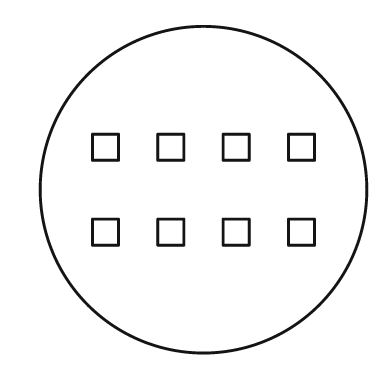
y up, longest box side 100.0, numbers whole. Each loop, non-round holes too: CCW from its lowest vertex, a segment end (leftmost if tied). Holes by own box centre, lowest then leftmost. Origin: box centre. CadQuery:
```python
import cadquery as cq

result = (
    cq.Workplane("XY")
    .moveTo(0.0, 0.0)
    .circle(50.0)
    .moveTo(-34.0, -17.0)
    .lineTo(-26.0, -17.0)
    .lineTo(-26.0, -9.0)
    .lineTo(-34.0, -9.0)
    .close()
    .moveTo(-14.0, -17.0)
    .lineTo(-6.0, -17.0)
    .lineTo(-6.0, -9.0)
    .lineTo(-14.0, -9.0)
    .close()
    .moveTo(6.0, -17.0)
    .lineTo(14.0, -17.0)
    .lineTo(14.0, -9.0)
    .lineTo(6.0, -9.0)
    .close()
    .moveTo(26.0, -17.0)
    .lineTo(34.0, -17.0)
    .lineTo(34.0, -9.0)
    .lineTo(26.0, -9.0)
    .close()
    .moveTo(-34.0, 9.0)
    .lineTo(-26.0, 9.0)
    .lineTo(-26.0, 17.0)
    .lineTo(-34.0, 17.0)
    .close()
    .moveTo(-14.0, 9.0)
    .lineTo(-6.0, 9.0)
    .lineTo(-6.0, 17.0)
    .lineTo(-14.0, 17.0)
    .close()
    .moveTo(6.0, 9.0)
    .lineTo(14.0, 9.0)
    .lineTo(14.0, 17.0)
    .lineTo(6.0, 17.0)
    .close()
    .moveTo(26.0, 9.0)
    .lineTo(34.0, 9.0)
    .lineTo(34.0, 17.0)
    .lineTo(26.0, 17.0)
    .close()
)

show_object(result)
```